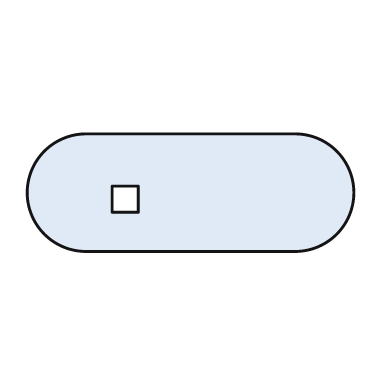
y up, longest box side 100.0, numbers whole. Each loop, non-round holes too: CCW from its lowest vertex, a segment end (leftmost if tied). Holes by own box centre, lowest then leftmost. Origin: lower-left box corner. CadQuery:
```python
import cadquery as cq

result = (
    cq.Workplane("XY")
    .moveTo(18.0, 0.0)
    .lineTo(82.0, 0.0)
    .threePointArc((100.0, 18.0), (82.0, 36.0))
    .lineTo(18.0, 36.0)
    .threePointArc((0.0, 18.0), (18.0, 0.0))
    .close()
    .moveTo(26.0, 12.0)
    .lineTo(34.0, 12.0)
    .lineTo(34.0, 20.0)
    .lineTo(26.0, 20.0)
    .close()
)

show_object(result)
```